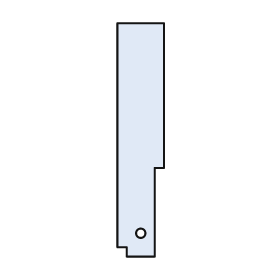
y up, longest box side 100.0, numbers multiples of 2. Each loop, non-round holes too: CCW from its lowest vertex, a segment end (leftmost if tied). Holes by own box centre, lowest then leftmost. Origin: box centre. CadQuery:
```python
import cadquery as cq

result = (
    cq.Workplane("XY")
    .moveTo(-6.0, -50.0)
    .lineTo(6.0, -50.0)
    .lineTo(6.0, -12.0)
    .lineTo(10.0, -12.0)
    .lineTo(10.0, 50.0)
    .lineTo(-10.0, 50.0)
    .lineTo(-10.0, -46.0)
    .lineTo(-6.0, -46.0)
    .close()
    .moveTo(0.0, -40.0)
    .circle(2.0)
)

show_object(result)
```